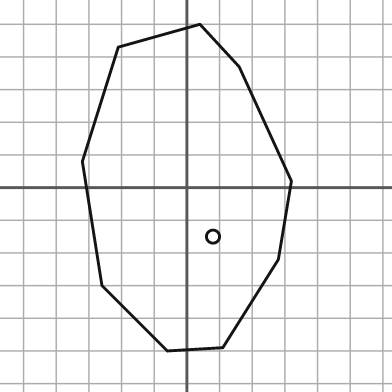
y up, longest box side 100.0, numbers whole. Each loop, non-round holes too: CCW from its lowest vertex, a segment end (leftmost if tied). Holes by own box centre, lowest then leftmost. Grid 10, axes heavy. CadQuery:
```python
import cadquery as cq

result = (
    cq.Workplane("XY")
    .moveTo(-6.0, -50.0)
    .lineTo(11.0, -49.0)
    .lineTo(28.0, -22.0)
    .lineTo(32.0, 2.0)
    .lineTo(16.0, 37.0)
    .lineTo(4.0, 50.0)
    .lineTo(-21.0, 43.0)
    .lineTo(-32.0, 8.0)
    .lineTo(-26.0, -30.0)
    .close()
    .moveTo(8.0, -15.0)
    .circle(2.0)
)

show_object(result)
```